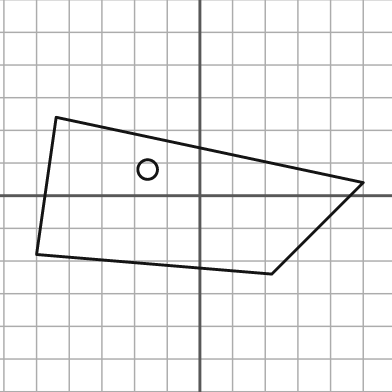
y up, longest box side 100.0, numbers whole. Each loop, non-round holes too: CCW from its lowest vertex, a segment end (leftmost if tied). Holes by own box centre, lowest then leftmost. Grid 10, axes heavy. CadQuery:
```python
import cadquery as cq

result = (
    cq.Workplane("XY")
    .moveTo(22.0, -24.0)
    .lineTo(50.0, 4.0)
    .lineTo(-44.0, 24.0)
    .lineTo(-50.0, -18.0)
    .close()
    .moveTo(-16.0, 8.0)
    .circle(3.0)
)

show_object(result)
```